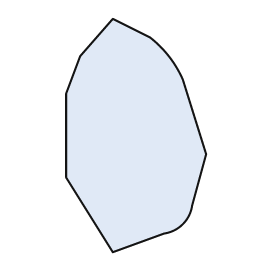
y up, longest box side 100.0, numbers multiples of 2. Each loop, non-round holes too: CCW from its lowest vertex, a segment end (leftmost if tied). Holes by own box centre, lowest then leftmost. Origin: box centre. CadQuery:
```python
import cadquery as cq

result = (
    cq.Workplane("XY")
    .moveTo(-10.0, -50.0)
    .lineTo(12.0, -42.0)
    .threePointArc((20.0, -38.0), (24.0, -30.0))
    .lineTo(30.0, -8.0)
    .lineTo(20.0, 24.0)
    .threePointArc((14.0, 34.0), (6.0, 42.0))
    .lineTo(-10.0, 50.0)
    .lineTo(-24.0, 34.0)
    .lineTo(-30.0, 18.0)
    .lineTo(-30.0, -18.0)
    .close()
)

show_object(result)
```